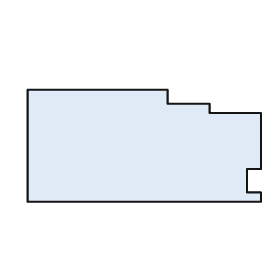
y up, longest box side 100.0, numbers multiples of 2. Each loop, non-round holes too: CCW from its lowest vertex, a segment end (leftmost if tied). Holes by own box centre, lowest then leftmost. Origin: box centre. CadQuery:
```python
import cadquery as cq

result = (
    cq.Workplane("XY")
    .moveTo(-50.0, -24.0)
    .lineTo(50.0, -24.0)
    .lineTo(50.0, -20.0)
    .lineTo(44.0, -20.0)
    .lineTo(44.0, -10.0)
    .lineTo(50.0, -10.0)
    .lineTo(50.0, 14.0)
    .lineTo(28.0, 14.0)
    .lineTo(28.0, 18.0)
    .lineTo(10.0, 18.0)
    .lineTo(10.0, 24.0)
    .lineTo(-50.0, 24.0)
    .close()
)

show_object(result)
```